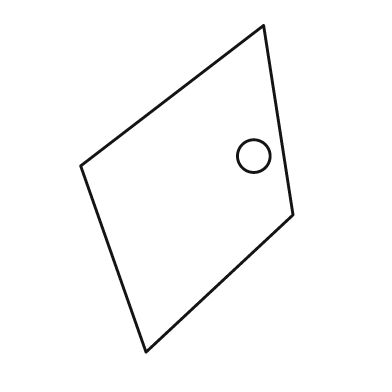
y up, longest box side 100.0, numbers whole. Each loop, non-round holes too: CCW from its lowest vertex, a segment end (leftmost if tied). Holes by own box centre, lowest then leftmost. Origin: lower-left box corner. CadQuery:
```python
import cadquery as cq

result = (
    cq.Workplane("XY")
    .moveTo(20.0, 0.0)
    .lineTo(65.0, 42.0)
    .lineTo(56.0, 100.0)
    .lineTo(0.0, 57.0)
    .close()
    .moveTo(53.0, 60.0)
    .circle(5.0)
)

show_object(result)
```